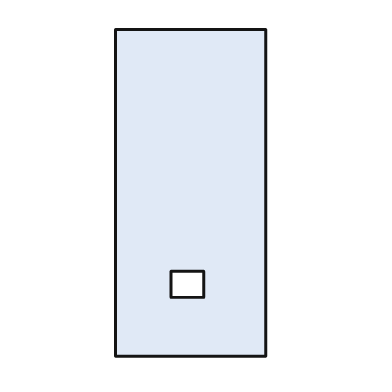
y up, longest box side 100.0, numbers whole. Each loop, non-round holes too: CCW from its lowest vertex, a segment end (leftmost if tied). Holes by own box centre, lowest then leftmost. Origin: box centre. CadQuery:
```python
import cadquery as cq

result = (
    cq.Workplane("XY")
    .moveTo(-23.0, -50.0)
    .lineTo(23.0, -50.0)
    .lineTo(23.0, 50.0)
    .lineTo(-23.0, 50.0)
    .close()
    .moveTo(-6.0, -32.0)
    .lineTo(4.0, -32.0)
    .lineTo(4.0, -24.0)
    .lineTo(-6.0, -24.0)
    .close()
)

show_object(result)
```